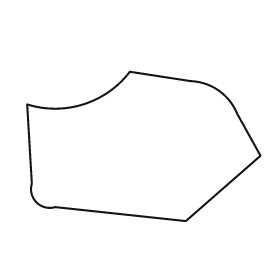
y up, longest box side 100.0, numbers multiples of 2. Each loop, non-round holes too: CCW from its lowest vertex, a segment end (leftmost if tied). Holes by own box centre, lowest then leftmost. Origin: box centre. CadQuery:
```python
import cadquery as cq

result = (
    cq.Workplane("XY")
    .moveTo(18.0, -32.0)
    .lineTo(50.0, -4.0)
    .lineTo(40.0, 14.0)
    .threePointArc((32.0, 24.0), (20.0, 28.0))
    .lineTo(-6.0, 32.0)
    .threePointArc((-26.0, 18.0), (-50.0, 18.0))
    .lineTo(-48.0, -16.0)
    .threePointArc((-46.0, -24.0), (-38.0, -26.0))
    .close()
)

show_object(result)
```